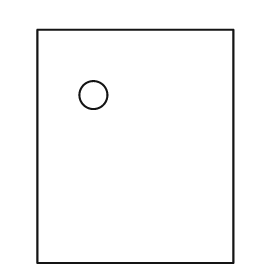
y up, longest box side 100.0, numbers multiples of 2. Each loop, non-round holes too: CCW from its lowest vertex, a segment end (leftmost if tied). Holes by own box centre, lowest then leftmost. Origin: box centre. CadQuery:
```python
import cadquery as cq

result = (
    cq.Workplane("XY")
    .moveTo(-42.0, -50.0)
    .lineTo(42.0, -50.0)
    .lineTo(42.0, 50.0)
    .lineTo(-42.0, 50.0)
    .close()
    .moveTo(-18.0, 22.0)
    .circle(6.0)
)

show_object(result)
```